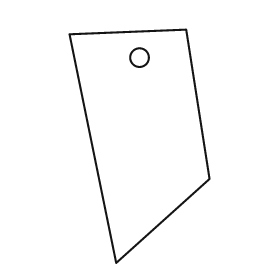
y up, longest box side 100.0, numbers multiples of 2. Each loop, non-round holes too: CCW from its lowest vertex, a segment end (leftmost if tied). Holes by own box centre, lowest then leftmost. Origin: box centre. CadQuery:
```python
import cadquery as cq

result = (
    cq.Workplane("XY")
    .moveTo(-10.0, -50.0)
    .lineTo(30.0, -14.0)
    .lineTo(20.0, 50.0)
    .lineTo(-30.0, 48.0)
    .close()
    .moveTo(0.0, 38.0)
    .circle(4.0)
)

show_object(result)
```